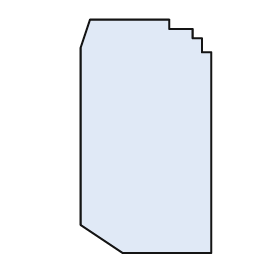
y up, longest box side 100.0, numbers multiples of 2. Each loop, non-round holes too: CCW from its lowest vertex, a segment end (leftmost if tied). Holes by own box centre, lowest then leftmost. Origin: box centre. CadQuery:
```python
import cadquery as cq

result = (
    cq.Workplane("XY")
    .moveTo(-10.0, -50.0)
    .lineTo(28.0, -50.0)
    .lineTo(28.0, 36.0)
    .lineTo(24.0, 36.0)
    .lineTo(24.0, 42.0)
    .lineTo(20.0, 42.0)
    .lineTo(20.0, 46.0)
    .lineTo(10.0, 46.0)
    .lineTo(10.0, 50.0)
    .lineTo(-24.0, 50.0)
    .lineTo(-28.0, 38.0)
    .lineTo(-28.0, -38.0)
    .close()
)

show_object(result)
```